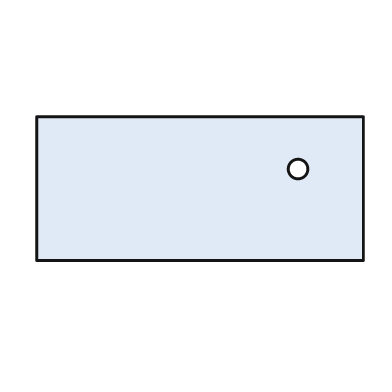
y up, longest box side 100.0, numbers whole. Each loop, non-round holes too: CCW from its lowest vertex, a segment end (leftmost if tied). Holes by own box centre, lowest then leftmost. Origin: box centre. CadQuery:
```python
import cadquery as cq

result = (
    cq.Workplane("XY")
    .moveTo(-50.0, -22.0)
    .lineTo(50.0, -22.0)
    .lineTo(50.0, 22.0)
    .lineTo(-50.0, 22.0)
    .close()
    .moveTo(30.0, 6.0)
    .circle(3.0)
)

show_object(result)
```